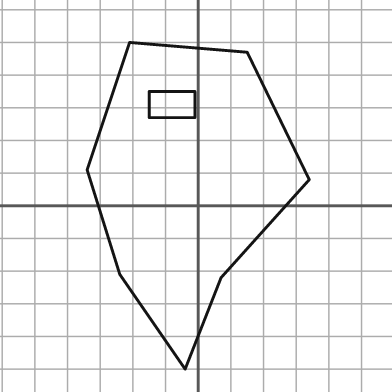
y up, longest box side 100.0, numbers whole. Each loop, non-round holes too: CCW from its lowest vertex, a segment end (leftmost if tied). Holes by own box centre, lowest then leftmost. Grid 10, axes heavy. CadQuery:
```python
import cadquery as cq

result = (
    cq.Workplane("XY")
    .moveTo(-4.0, -50.0)
    .lineTo(7.0, -22.0)
    .lineTo(34.0, 8.0)
    .lineTo(15.0, 47.0)
    .lineTo(-21.0, 50.0)
    .lineTo(-34.0, 11.0)
    .lineTo(-24.0, -21.0)
    .close()
    .moveTo(-15.0, 27.0)
    .lineTo(-1.0, 27.0)
    .lineTo(-1.0, 35.0)
    .lineTo(-15.0, 35.0)
    .close()
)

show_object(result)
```